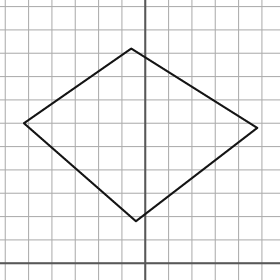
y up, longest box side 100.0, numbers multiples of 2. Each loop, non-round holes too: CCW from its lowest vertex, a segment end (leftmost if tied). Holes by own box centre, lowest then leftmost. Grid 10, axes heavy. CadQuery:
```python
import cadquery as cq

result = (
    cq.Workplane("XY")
    .moveTo(-4.0, 18.0)
    .lineTo(48.0, 58.0)
    .lineTo(-6.0, 92.0)
    .lineTo(-52.0, 60.0)
    .close()
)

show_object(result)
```